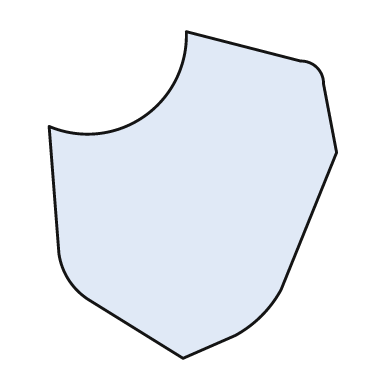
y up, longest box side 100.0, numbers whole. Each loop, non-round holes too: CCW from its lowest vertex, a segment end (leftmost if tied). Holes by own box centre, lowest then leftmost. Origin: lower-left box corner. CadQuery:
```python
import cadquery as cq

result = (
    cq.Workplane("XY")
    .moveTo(41.0, 0.0)
    .lineTo(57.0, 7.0)
    .threePointArc((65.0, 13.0), (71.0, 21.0))
    .lineTo(88.0, 63.0)
    .lineTo(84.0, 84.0)
    .threePointArc((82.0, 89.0), (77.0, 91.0))
    .lineTo(42.0, 100.0)
    .threePointArc((29.0, 74.0), (0.0, 71.0))
    .lineTo(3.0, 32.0)
    .threePointArc((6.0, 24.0), (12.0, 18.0))
    .close()
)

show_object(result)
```